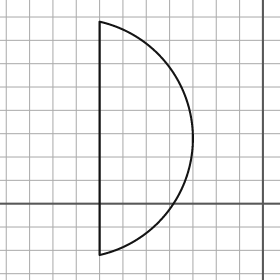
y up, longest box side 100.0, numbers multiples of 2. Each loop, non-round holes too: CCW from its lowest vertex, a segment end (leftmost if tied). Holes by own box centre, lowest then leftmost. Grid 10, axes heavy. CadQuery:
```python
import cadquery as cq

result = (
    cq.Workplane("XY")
    .moveTo(-70.0, -22.0)
    .threePointArc((-30.0, 28.0), (-70.0, 78.0))
    .close()
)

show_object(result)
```